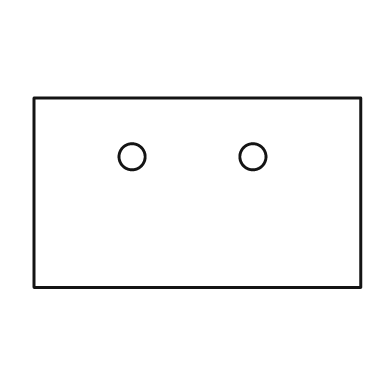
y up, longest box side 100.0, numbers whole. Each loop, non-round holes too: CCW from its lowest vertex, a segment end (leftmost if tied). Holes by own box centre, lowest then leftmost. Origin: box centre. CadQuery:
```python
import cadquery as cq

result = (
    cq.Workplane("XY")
    .moveTo(-50.0, -29.0)
    .lineTo(50.0, -29.0)
    .lineTo(50.0, 29.0)
    .lineTo(-50.0, 29.0)
    .close()
    .moveTo(-20.0, 11.0)
    .circle(4.0)
    .moveTo(17.0, 11.0)
    .circle(4.0)
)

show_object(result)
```